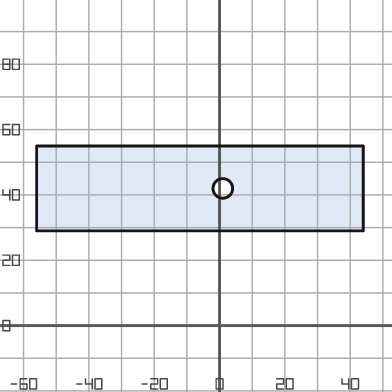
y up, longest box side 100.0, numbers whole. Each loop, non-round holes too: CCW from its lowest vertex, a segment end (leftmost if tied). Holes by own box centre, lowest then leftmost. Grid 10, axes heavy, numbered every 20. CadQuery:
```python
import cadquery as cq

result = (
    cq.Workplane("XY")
    .moveTo(-56.0, 29.0)
    .lineTo(44.0, 29.0)
    .lineTo(44.0, 55.0)
    .lineTo(-56.0, 55.0)
    .close()
    .moveTo(1.0, 42.0)
    .circle(3.0)
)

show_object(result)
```